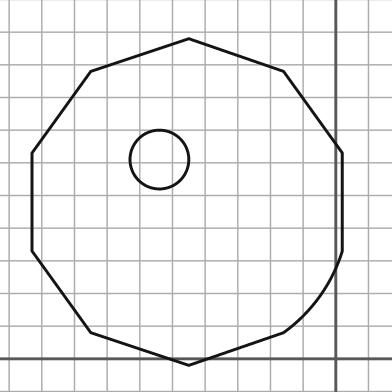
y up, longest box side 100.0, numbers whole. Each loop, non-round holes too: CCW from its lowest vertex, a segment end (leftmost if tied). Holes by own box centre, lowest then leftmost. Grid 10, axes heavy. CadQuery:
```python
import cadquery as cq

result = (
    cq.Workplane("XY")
    .moveTo(-45.0, -2.0)
    .lineTo(-16.0, 8.0)
    .threePointArc((-5.0, 19.0), (2.0, 33.0))
    .lineTo(2.0, 63.0)
    .lineTo(-16.0, 88.0)
    .lineTo(-45.0, 98.0)
    .lineTo(-75.0, 88.0)
    .lineTo(-93.0, 63.0)
    .lineTo(-93.0, 33.0)
    .lineTo(-75.0, 8.0)
    .close()
    .moveTo(-54.0, 61.0)
    .circle(9.0)
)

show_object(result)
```